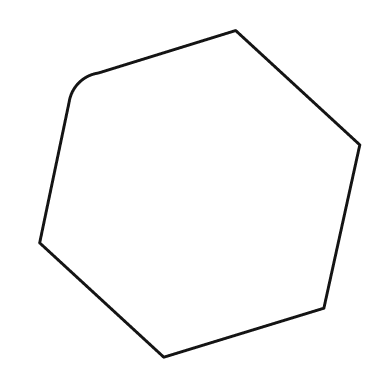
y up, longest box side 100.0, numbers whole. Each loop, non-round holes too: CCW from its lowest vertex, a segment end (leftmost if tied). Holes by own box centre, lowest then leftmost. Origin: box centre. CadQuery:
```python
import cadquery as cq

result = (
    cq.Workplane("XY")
    .moveTo(-11.0, -50.0)
    .lineTo(38.0, -35.0)
    .lineTo(49.0, 15.0)
    .lineTo(11.0, 50.0)
    .lineTo(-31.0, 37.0)
    .threePointArc((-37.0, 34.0), (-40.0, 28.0))
    .lineTo(-49.0, -15.0)
    .close()
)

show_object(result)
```